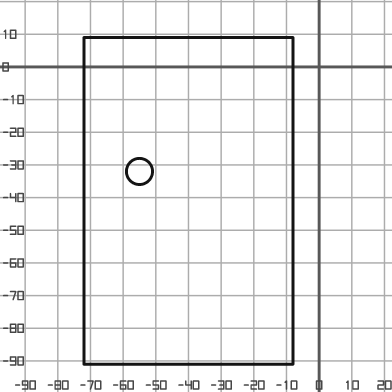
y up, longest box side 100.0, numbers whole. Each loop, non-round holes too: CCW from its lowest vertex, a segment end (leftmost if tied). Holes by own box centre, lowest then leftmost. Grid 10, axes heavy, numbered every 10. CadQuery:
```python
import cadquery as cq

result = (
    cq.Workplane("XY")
    .moveTo(-72.0, -91.0)
    .lineTo(-8.0, -91.0)
    .lineTo(-8.0, 9.0)
    .lineTo(-72.0, 9.0)
    .close()
    .moveTo(-55.0, -32.0)
    .circle(4.0)
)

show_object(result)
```